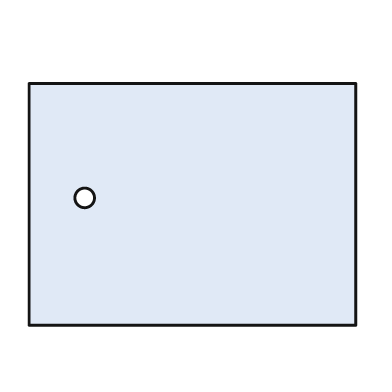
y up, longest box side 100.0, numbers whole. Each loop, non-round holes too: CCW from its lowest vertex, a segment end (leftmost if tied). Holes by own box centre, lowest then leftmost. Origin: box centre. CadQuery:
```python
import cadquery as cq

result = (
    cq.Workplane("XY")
    .moveTo(-50.0, -37.0)
    .lineTo(50.0, -37.0)
    .lineTo(50.0, 37.0)
    .lineTo(-50.0, 37.0)
    .close()
    .moveTo(-33.0, 2.0)
    .circle(3.0)
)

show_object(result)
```